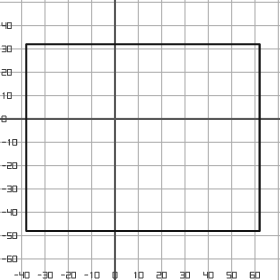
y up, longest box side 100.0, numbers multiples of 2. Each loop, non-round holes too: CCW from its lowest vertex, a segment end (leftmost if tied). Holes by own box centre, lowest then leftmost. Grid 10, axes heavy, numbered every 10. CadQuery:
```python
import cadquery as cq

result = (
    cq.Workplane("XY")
    .moveTo(-38.0, -48.0)
    .lineTo(62.0, -48.0)
    .lineTo(62.0, 32.0)
    .lineTo(-38.0, 32.0)
    .close()
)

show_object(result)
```